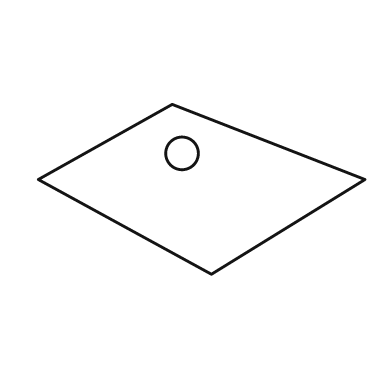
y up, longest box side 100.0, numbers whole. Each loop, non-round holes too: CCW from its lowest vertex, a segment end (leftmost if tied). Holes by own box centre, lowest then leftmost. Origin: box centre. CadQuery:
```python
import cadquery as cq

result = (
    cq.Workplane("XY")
    .moveTo(3.0, -26.0)
    .lineTo(50.0, 3.0)
    .lineTo(-9.0, 26.0)
    .lineTo(-50.0, 3.0)
    .close()
    .moveTo(-6.0, 11.0)
    .circle(5.0)
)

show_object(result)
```